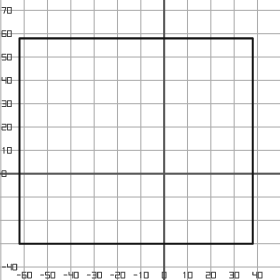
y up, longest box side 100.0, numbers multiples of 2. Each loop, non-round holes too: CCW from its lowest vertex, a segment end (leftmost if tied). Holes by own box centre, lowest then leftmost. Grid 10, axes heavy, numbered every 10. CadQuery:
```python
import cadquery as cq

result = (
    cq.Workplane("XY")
    .moveTo(-62.0, -30.0)
    .lineTo(38.0, -30.0)
    .lineTo(38.0, 58.0)
    .lineTo(-62.0, 58.0)
    .close()
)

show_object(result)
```